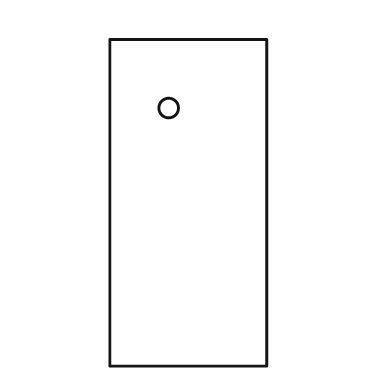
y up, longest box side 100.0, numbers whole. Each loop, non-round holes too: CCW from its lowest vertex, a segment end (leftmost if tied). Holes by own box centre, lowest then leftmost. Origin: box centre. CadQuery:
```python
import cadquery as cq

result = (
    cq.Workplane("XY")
    .moveTo(-24.0, -50.0)
    .lineTo(24.0, -50.0)
    .lineTo(24.0, 50.0)
    .lineTo(-24.0, 50.0)
    .close()
    .moveTo(-6.0, 29.0)
    .circle(3.0)
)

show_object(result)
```